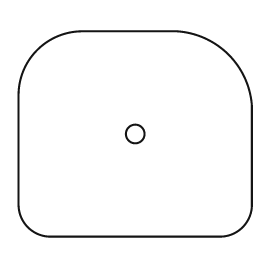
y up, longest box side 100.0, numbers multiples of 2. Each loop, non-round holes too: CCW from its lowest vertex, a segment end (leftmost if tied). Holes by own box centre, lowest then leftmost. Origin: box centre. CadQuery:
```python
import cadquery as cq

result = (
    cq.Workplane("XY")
    .moveTo(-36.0, -44.0)
    .lineTo(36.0, -44.0)
    .threePointArc((46.0, -40.0), (50.0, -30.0))
    .lineTo(50.0, 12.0)
    .threePointArc((40.0, 34.0), (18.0, 44.0))
    .lineTo(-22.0, 44.0)
    .threePointArc((-42.0, 36.0), (-50.0, 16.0))
    .lineTo(-50.0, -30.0)
    .threePointArc((-46.0, -40.0), (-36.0, -44.0))
    .close()
    .moveTo(0.0, 0.0)
    .circle(4.0)
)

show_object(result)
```